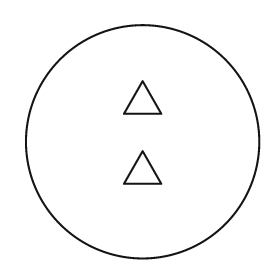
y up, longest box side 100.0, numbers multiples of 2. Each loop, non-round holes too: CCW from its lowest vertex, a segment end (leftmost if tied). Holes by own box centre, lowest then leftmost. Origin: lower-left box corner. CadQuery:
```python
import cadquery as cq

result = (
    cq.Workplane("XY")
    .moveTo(50.0, 50.0)
    .circle(50.0)
    .moveTo(42.0, 32.0)
    .lineTo(58.0, 32.0)
    .lineTo(50.0, 46.0)
    .close()
    .moveTo(42.0, 62.0)
    .lineTo(58.0, 62.0)
    .lineTo(50.0, 76.0)
    .close()
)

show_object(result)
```